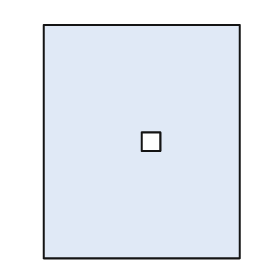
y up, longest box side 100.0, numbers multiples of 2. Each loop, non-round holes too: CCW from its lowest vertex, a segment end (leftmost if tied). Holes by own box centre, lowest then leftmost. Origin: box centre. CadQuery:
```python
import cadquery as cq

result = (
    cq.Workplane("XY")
    .moveTo(-42.0, -50.0)
    .lineTo(42.0, -50.0)
    .lineTo(42.0, 50.0)
    .lineTo(-42.0, 50.0)
    .close()
    .moveTo(0.0, -4.0)
    .lineTo(8.0, -4.0)
    .lineTo(8.0, 4.0)
    .lineTo(0.0, 4.0)
    .close()
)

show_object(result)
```